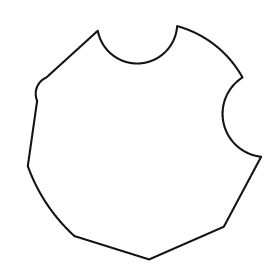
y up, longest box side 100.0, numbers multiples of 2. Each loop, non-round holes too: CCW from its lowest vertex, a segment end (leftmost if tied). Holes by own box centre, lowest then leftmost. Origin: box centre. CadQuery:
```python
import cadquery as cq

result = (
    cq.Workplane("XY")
    .moveTo(2.0, -50.0)
    .lineTo(34.0, -36.0)
    .lineTo(50.0, -6.0)
    .threePointArc((34.0, 8.0), (42.0, 28.0))
    .threePointArc((30.0, 42.0), (14.0, 50.0))
    .threePointArc((-2.0, 34.0), (-20.0, 48.0))
    .lineTo(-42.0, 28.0)
    .threePointArc((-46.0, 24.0), (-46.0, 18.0))
    .lineTo(-50.0, -10.0)
    .threePointArc((-42.0, -26.0), (-30.0, -40.0))
    .close()
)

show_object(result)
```